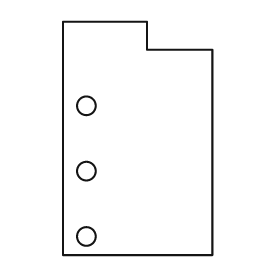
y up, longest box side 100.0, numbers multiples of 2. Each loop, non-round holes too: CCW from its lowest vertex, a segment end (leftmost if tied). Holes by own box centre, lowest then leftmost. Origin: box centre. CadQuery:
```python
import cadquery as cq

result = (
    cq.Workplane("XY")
    .moveTo(-32.0, -50.0)
    .lineTo(32.0, -50.0)
    .lineTo(32.0, 38.0)
    .lineTo(4.0, 38.0)
    .lineTo(4.0, 50.0)
    .lineTo(-32.0, 50.0)
    .close()
    .moveTo(-22.0, -42.0)
    .circle(4.0)
    .moveTo(-22.0, -14.0)
    .circle(4.0)
    .moveTo(-22.0, 14.0)
    .circle(4.0)
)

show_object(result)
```